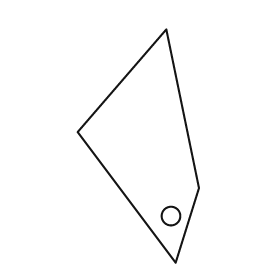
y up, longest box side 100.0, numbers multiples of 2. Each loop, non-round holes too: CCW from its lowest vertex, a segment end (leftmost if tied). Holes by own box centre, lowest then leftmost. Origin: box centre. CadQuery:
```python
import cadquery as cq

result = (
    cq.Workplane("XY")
    .moveTo(16.0, -50.0)
    .lineTo(26.0, -18.0)
    .lineTo(12.0, 50.0)
    .lineTo(-26.0, 6.0)
    .close()
    .moveTo(14.0, -30.0)
    .circle(4.0)
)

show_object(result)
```